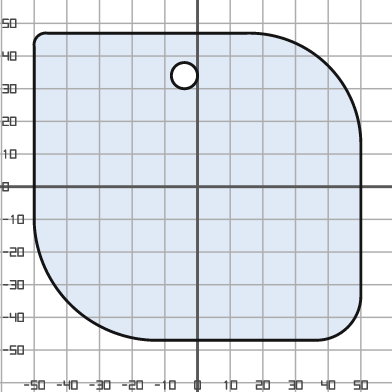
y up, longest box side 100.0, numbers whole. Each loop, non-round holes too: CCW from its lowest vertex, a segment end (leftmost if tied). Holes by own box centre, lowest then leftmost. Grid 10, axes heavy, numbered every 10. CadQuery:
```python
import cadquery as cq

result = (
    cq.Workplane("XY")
    .moveTo(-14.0, -47.0)
    .lineTo(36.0, -47.0)
    .threePointArc((46.0, -43.0), (50.0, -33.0))
    .lineTo(50.0, 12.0)
    .threePointArc((40.0, 37.0), (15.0, 47.0))
    .lineTo(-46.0, 47.0)
    .threePointArc((-49.0, 46.0), (-50.0, 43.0))
    .lineTo(-50.0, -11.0)
    .threePointArc((-39.0, -36.0), (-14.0, -47.0))
    .close()
    .moveTo(-4.0, 34.0)
    .circle(4.0)
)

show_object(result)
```